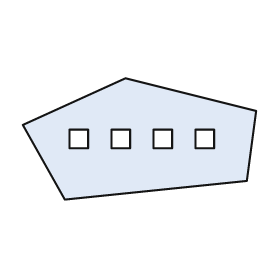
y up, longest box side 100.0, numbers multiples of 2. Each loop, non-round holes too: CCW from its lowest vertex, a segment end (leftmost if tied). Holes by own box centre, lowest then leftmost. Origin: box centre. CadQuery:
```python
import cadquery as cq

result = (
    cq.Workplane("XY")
    .moveTo(-32.0, -26.0)
    .lineTo(46.0, -18.0)
    .lineTo(50.0, 12.0)
    .lineTo(-6.0, 26.0)
    .lineTo(-50.0, 6.0)
    .close()
    .moveTo(-30.0, -4.0)
    .lineTo(-22.0, -4.0)
    .lineTo(-22.0, 4.0)
    .lineTo(-30.0, 4.0)
    .close()
    .moveTo(-12.0, -4.0)
    .lineTo(-4.0, -4.0)
    .lineTo(-4.0, 4.0)
    .lineTo(-12.0, 4.0)
    .close()
    .moveTo(6.0, -4.0)
    .lineTo(14.0, -4.0)
    .lineTo(14.0, 4.0)
    .lineTo(6.0, 4.0)
    .close()
    .moveTo(24.0, -4.0)
    .lineTo(32.0, -4.0)
    .lineTo(32.0, 4.0)
    .lineTo(24.0, 4.0)
    .close()
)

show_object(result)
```